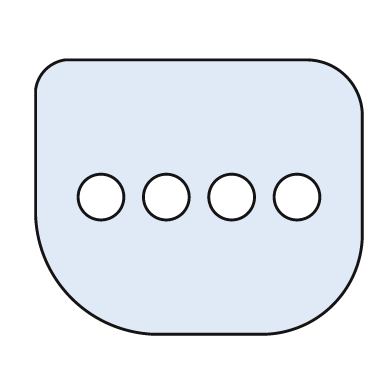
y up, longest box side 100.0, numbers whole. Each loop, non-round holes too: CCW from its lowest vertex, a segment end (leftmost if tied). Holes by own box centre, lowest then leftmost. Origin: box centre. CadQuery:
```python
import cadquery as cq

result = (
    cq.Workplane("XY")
    .moveTo(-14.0, -42.0)
    .lineTo(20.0, -42.0)
    .threePointArc((41.0, -33.0), (50.0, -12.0))
    .lineTo(50.0, 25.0)
    .threePointArc((45.0, 37.0), (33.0, 42.0))
    .lineTo(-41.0, 42.0)
    .threePointArc((-47.0, 39.0), (-50.0, 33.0))
    .lineTo(-50.0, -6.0)
    .threePointArc((-39.0, -31.0), (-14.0, -42.0))
    .close()
    .moveTo(-30.0, 0.0)
    .circle(7.0)
    .moveTo(-10.0, 0.0)
    .circle(7.0)
    .moveTo(10.0, 0.0)
    .circle(7.0)
    .moveTo(30.0, 0.0)
    .circle(7.0)
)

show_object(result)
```